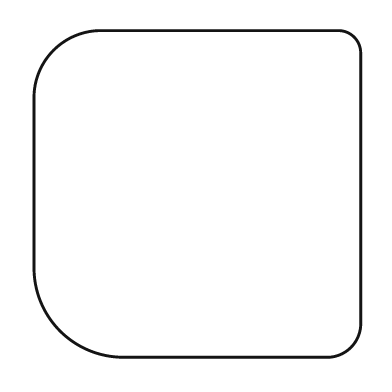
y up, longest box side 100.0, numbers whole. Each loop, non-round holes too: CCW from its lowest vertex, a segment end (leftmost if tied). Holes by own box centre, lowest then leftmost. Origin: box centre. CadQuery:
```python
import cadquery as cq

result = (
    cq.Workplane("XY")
    .moveTo(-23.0, -50.0)
    .lineTo(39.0, -50.0)
    .threePointArc((47.0, -47.0), (50.0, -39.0))
    .lineTo(50.0, 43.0)
    .threePointArc((48.0, 48.0), (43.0, 50.0))
    .lineTo(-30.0, 50.0)
    .threePointArc((-44.0, 44.0), (-50.0, 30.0))
    .lineTo(-50.0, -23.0)
    .threePointArc((-42.0, -42.0), (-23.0, -50.0))
    .close()
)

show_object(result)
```